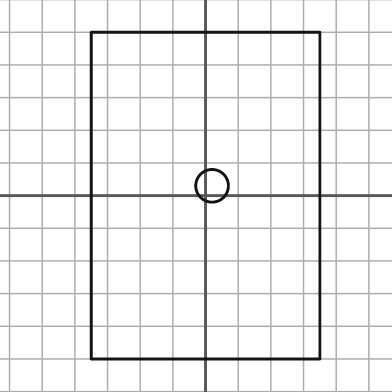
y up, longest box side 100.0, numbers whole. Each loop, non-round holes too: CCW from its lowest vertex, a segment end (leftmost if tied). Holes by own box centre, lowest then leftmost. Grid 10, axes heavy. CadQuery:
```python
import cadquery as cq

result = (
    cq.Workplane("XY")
    .moveTo(-35.0, -50.0)
    .lineTo(35.0, -50.0)
    .lineTo(35.0, 50.0)
    .lineTo(-35.0, 50.0)
    .close()
    .moveTo(2.0, 3.0)
    .circle(5.0)
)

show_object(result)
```